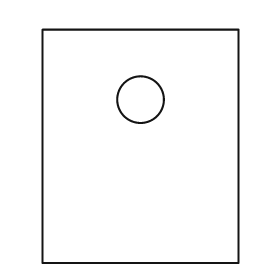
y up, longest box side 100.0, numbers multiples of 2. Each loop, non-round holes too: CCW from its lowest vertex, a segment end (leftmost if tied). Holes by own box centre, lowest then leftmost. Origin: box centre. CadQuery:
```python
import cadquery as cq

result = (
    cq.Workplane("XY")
    .moveTo(-42.0, -50.0)
    .lineTo(42.0, -50.0)
    .lineTo(42.0, 50.0)
    .lineTo(-42.0, 50.0)
    .close()
    .moveTo(0.0, 20.0)
    .circle(10.0)
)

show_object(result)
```